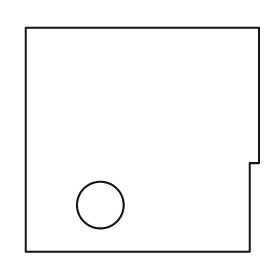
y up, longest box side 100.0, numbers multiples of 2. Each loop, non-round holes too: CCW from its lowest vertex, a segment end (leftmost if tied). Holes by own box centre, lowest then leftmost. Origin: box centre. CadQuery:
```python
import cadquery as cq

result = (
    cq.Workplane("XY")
    .moveTo(-50.0, -48.0)
    .lineTo(46.0, -48.0)
    .lineTo(46.0, -10.0)
    .lineTo(50.0, -10.0)
    .lineTo(50.0, 48.0)
    .lineTo(-50.0, 48.0)
    .close()
    .moveTo(-18.0, -28.0)
    .circle(10.0)
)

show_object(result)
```